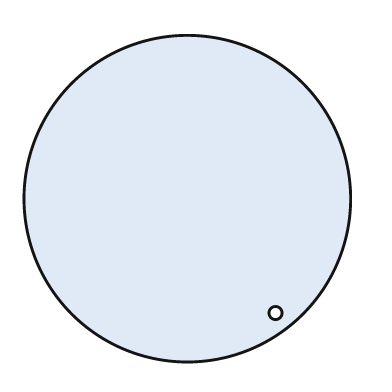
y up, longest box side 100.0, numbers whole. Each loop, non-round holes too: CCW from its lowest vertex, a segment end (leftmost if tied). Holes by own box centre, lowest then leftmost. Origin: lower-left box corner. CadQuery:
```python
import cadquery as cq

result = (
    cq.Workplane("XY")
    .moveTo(50.0, 50.0)
    .circle(50.0)
    .moveTo(77.0, 15.0)
    .circle(2.0)
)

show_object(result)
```